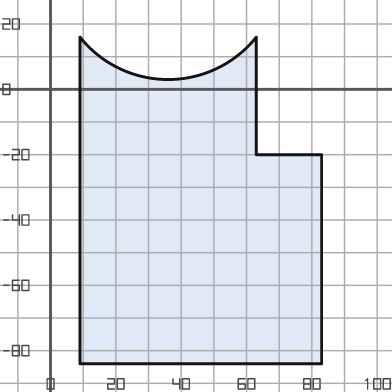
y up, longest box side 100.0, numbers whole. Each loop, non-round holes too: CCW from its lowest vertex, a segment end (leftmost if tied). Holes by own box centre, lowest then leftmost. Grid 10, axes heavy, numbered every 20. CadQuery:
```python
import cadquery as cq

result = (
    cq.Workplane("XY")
    .moveTo(9.0, -84.0)
    .lineTo(83.0, -84.0)
    .lineTo(83.0, -20.0)
    .lineTo(63.0, -20.0)
    .lineTo(63.0, 16.0)
    .threePointArc((36.0, 3.0), (9.0, 16.0))
    .close()
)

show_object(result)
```